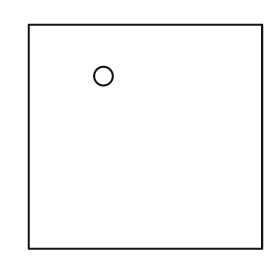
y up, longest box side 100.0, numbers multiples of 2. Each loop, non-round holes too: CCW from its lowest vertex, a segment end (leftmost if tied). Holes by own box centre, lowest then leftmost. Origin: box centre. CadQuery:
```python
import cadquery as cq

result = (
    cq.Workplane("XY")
    .moveTo(-50.0, -48.0)
    .lineTo(50.0, -48.0)
    .lineTo(50.0, 48.0)
    .lineTo(-50.0, 48.0)
    .close()
    .moveTo(-18.0, 26.0)
    .circle(4.0)
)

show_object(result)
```